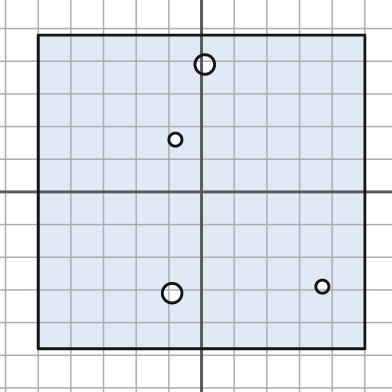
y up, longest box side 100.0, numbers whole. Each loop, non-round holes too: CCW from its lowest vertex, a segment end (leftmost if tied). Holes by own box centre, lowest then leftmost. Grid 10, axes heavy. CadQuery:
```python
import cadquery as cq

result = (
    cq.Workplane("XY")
    .moveTo(-50.0, -48.0)
    .lineTo(50.0, -48.0)
    .lineTo(50.0, 48.0)
    .lineTo(-50.0, 48.0)
    .close()
    .moveTo(-9.0, -31.0)
    .circle(3.0)
    .moveTo(37.0, -29.0)
    .circle(2.0)
    .moveTo(-8.0, 16.0)
    .circle(2.0)
    .moveTo(1.0, 39.0)
    .circle(3.0)
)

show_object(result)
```